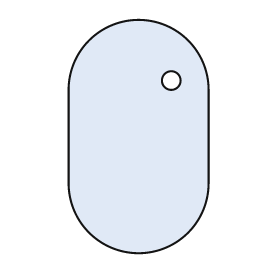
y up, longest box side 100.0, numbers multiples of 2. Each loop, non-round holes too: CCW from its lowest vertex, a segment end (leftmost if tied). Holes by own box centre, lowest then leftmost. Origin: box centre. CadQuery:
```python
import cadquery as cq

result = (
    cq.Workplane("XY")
    .moveTo(-30.0, -20.0)
    .threePointArc((0.0, -50.0), (30.0, -20.0))
    .lineTo(30.0, 20.0)
    .threePointArc((0.0, 50.0), (-30.0, 20.0))
    .close()
    .moveTo(14.0, 24.0)
    .circle(4.0)
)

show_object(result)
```